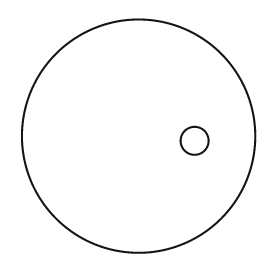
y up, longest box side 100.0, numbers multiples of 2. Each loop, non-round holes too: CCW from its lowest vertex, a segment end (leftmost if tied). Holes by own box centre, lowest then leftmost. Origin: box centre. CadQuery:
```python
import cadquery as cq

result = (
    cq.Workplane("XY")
    .moveTo(0.0, 0.0)
    .circle(50.0)
    .moveTo(24.0, -2.0)
    .circle(6.0)
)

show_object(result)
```